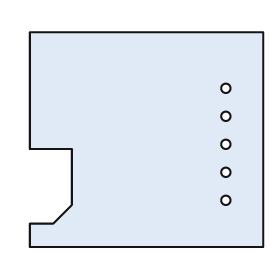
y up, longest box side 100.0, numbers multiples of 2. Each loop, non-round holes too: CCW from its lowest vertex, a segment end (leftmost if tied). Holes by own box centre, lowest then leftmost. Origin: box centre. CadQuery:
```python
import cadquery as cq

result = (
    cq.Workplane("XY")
    .moveTo(-50.0, -46.0)
    .lineTo(50.0, -46.0)
    .lineTo(50.0, 46.0)
    .lineTo(-50.0, 46.0)
    .lineTo(-50.0, -4.0)
    .lineTo(-32.0, -4.0)
    .lineTo(-32.0, -28.0)
    .lineTo(-40.0, -36.0)
    .lineTo(-50.0, -36.0)
    .close()
    .moveTo(34.0, -26.0)
    .circle(2.0)
    .moveTo(34.0, -14.0)
    .circle(2.0)
    .moveTo(34.0, -2.0)
    .circle(2.0)
    .moveTo(34.0, 10.0)
    .circle(2.0)
    .moveTo(34.0, 22.0)
    .circle(2.0)
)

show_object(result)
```